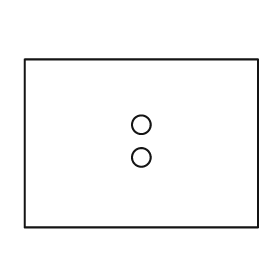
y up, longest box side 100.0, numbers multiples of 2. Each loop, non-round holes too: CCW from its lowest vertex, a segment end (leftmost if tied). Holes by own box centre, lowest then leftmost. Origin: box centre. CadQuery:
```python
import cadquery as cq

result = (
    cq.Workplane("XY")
    .moveTo(-50.0, -36.0)
    .lineTo(50.0, -36.0)
    .lineTo(50.0, 36.0)
    .lineTo(-50.0, 36.0)
    .close()
    .moveTo(0.0, -6.0)
    .circle(4.0)
    .moveTo(0.0, 8.0)
    .circle(4.0)
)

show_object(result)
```